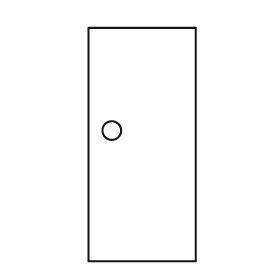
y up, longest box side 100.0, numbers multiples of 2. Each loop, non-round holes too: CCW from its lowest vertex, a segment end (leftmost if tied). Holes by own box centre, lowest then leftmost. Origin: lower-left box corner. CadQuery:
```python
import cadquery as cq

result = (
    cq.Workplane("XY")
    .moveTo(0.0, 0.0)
    .lineTo(46.0, 0.0)
    .lineTo(46.0, 100.0)
    .lineTo(0.0, 100.0)
    .close()
    .moveTo(10.0, 56.0)
    .circle(4.0)
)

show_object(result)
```